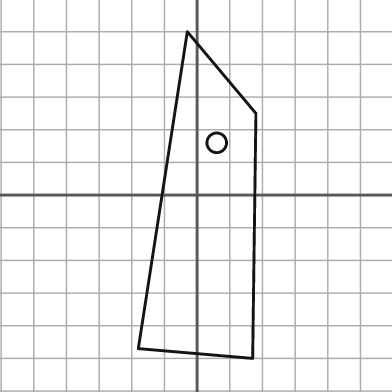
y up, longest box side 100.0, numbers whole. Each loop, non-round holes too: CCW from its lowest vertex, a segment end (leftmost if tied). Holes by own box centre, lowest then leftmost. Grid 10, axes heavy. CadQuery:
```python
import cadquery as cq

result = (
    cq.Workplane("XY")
    .moveTo(17.0, -50.0)
    .lineTo(18.0, 25.0)
    .lineTo(-3.0, 50.0)
    .lineTo(-18.0, -47.0)
    .close()
    .moveTo(6.0, 16.0)
    .circle(3.0)
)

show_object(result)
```